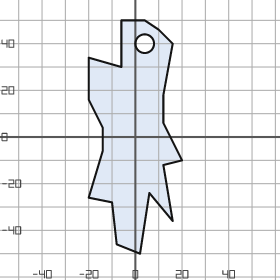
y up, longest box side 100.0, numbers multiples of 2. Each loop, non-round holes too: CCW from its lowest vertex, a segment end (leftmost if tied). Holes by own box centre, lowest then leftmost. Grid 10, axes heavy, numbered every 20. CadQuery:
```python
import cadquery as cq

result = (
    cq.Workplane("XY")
    .moveTo(2.0, -50.0)
    .lineTo(6.0, -24.0)
    .lineTo(16.0, -36.0)
    .lineTo(12.0, -12.0)
    .lineTo(20.0, -10.0)
    .lineTo(12.0, 6.0)
    .lineTo(12.0, 18.0)
    .lineTo(16.0, 40.0)
    .lineTo(10.0, 46.0)
    .lineTo(4.0, 50.0)
    .lineTo(-6.0, 50.0)
    .lineTo(-6.0, 30.0)
    .lineTo(-20.0, 34.0)
    .lineTo(-20.0, 16.0)
    .lineTo(-14.0, 4.0)
    .lineTo(-14.0, -6.0)
    .lineTo(-20.0, -26.0)
    .lineTo(-10.0, -28.0)
    .lineTo(-8.0, -46.0)
    .close()
    .moveTo(4.0, 40.0)
    .circle(4.0)
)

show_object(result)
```